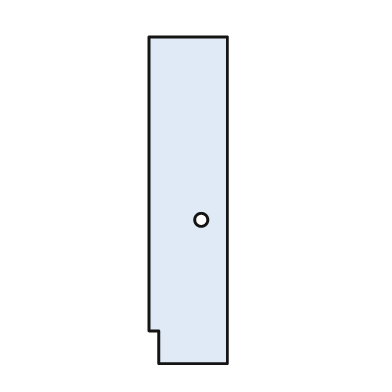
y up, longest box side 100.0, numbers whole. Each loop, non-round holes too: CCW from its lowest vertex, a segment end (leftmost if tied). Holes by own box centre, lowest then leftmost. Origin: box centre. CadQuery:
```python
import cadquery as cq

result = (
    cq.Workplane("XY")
    .moveTo(-9.0, -50.0)
    .lineTo(12.0, -50.0)
    .lineTo(12.0, 50.0)
    .lineTo(-12.0, 50.0)
    .lineTo(-12.0, -40.0)
    .lineTo(-9.0, -40.0)
    .close()
    .moveTo(4.0, -6.0)
    .circle(2.0)
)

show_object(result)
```